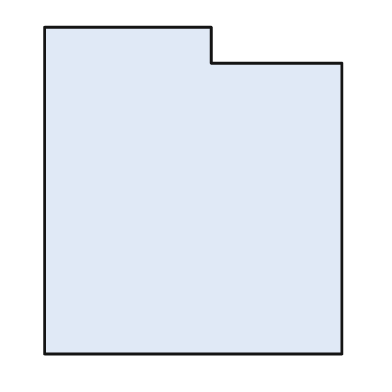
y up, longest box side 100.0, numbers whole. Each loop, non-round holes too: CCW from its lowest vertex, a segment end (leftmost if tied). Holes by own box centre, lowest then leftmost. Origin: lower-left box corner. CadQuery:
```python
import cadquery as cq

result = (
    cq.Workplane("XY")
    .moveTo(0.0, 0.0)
    .lineTo(91.0, 0.0)
    .lineTo(91.0, 89.0)
    .lineTo(51.0, 89.0)
    .lineTo(51.0, 100.0)
    .lineTo(0.0, 100.0)
    .close()
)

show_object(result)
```